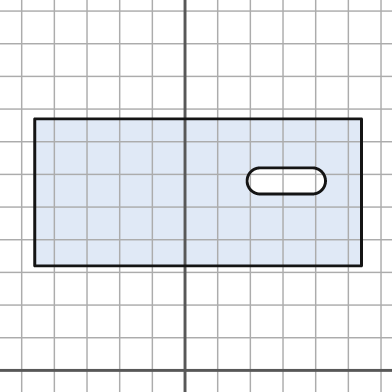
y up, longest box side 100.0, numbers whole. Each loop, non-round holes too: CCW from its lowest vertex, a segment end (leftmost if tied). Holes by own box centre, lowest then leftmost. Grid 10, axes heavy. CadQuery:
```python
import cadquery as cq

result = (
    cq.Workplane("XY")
    .moveTo(-46.0, 32.0)
    .lineTo(54.0, 32.0)
    .lineTo(54.0, 77.0)
    .lineTo(-46.0, 77.0)
    .close()
    .moveTo(23.0, 54.0)
    .lineTo(39.0, 54.0)
    .threePointArc((43.0, 58.0), (39.0, 62.0))
    .lineTo(23.0, 62.0)
    .threePointArc((19.0, 58.0), (23.0, 54.0))
    .close()
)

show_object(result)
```